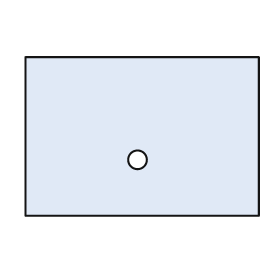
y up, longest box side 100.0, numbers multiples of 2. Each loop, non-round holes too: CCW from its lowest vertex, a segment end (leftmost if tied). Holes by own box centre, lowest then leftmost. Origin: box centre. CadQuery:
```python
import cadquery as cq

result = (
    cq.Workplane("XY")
    .moveTo(-50.0, -34.0)
    .lineTo(50.0, -34.0)
    .lineTo(50.0, 34.0)
    .lineTo(-50.0, 34.0)
    .close()
    .moveTo(-2.0, -10.0)
    .circle(4.0)
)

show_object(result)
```